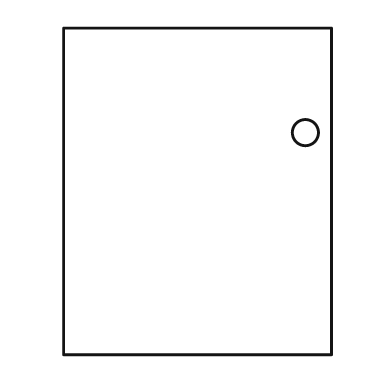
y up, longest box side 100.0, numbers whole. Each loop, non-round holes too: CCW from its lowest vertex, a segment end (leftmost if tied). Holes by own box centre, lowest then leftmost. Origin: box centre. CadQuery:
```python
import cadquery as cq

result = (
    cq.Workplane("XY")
    .moveTo(-41.0, -50.0)
    .lineTo(41.0, -50.0)
    .lineTo(41.0, 50.0)
    .lineTo(-41.0, 50.0)
    .close()
    .moveTo(33.0, 18.0)
    .circle(4.0)
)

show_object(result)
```